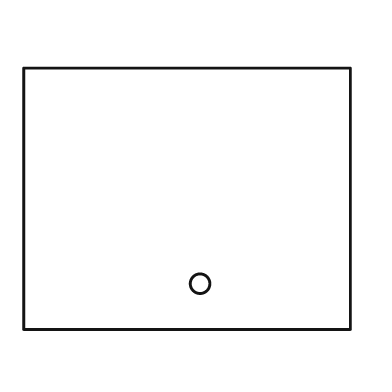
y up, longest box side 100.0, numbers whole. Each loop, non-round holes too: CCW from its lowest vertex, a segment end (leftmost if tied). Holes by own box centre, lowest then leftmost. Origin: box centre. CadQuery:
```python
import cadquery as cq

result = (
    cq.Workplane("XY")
    .moveTo(-50.0, -40.0)
    .lineTo(50.0, -40.0)
    .lineTo(50.0, 40.0)
    .lineTo(-50.0, 40.0)
    .close()
    .moveTo(4.0, -26.0)
    .circle(3.0)
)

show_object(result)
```